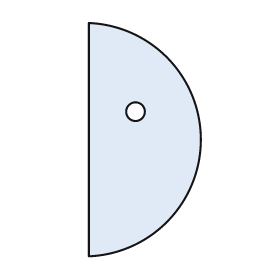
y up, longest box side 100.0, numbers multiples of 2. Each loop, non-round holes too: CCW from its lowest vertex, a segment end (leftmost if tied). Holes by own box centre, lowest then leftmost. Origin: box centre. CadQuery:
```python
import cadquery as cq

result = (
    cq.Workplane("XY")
    .moveTo(-24.0, -50.0)
    .threePointArc((24.0, 0.0), (-24.0, 50.0))
    .close()
    .moveTo(-4.0, 12.0)
    .circle(4.0)
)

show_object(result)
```